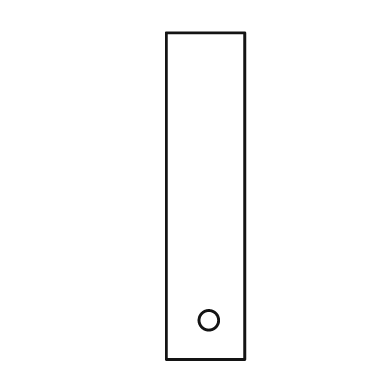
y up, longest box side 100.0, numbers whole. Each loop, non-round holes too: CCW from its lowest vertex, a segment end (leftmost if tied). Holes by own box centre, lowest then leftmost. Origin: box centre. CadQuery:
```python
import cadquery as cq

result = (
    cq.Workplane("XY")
    .moveTo(-12.0, -50.0)
    .lineTo(12.0, -50.0)
    .lineTo(12.0, 50.0)
    .lineTo(-12.0, 50.0)
    .close()
    .moveTo(1.0, -38.0)
    .circle(3.0)
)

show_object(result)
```